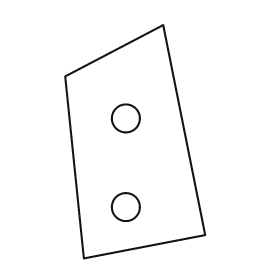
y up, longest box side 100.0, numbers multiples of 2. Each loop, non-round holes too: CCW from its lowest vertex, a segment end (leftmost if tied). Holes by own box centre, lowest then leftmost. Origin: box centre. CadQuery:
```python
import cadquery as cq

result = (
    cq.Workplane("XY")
    .moveTo(-22.0, -50.0)
    .lineTo(30.0, -40.0)
    .lineTo(12.0, 50.0)
    .lineTo(-30.0, 28.0)
    .close()
    .moveTo(-4.0, -28.0)
    .circle(6.0)
    .moveTo(-4.0, 10.0)
    .circle(6.0)
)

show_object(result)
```